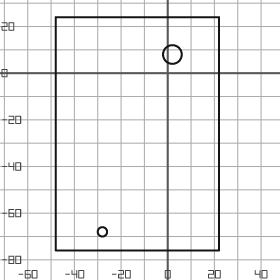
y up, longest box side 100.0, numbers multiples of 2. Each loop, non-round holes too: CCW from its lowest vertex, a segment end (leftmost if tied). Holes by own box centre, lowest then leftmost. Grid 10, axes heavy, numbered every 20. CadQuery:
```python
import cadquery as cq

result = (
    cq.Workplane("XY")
    .moveTo(-48.0, -76.0)
    .lineTo(22.0, -76.0)
    .lineTo(22.0, 24.0)
    .lineTo(-48.0, 24.0)
    .close()
    .moveTo(-28.0, -68.0)
    .circle(2.0)
    .moveTo(2.0, 8.0)
    .circle(4.0)
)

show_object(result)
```